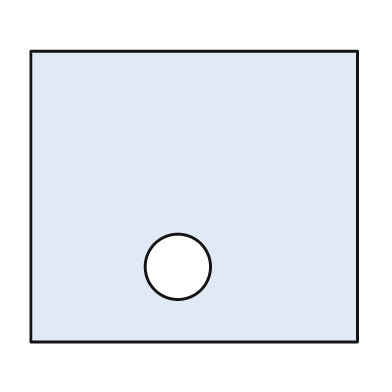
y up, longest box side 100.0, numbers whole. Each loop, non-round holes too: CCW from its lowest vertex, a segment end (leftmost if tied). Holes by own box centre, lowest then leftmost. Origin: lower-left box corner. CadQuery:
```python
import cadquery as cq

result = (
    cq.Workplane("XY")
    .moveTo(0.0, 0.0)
    .lineTo(100.0, 0.0)
    .lineTo(100.0, 89.0)
    .lineTo(0.0, 89.0)
    .close()
    .moveTo(45.0, 23.0)
    .circle(10.0)
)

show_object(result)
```